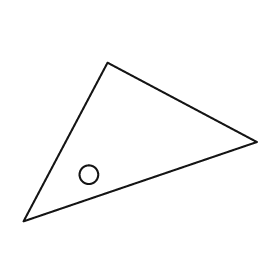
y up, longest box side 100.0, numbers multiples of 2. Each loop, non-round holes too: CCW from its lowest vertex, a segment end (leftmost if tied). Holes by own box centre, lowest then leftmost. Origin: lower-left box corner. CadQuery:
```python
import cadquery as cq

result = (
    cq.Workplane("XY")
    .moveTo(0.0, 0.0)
    .lineTo(100.0, 34.0)
    .lineTo(36.0, 68.0)
    .close()
    .moveTo(28.0, 20.0)
    .circle(4.0)
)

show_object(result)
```